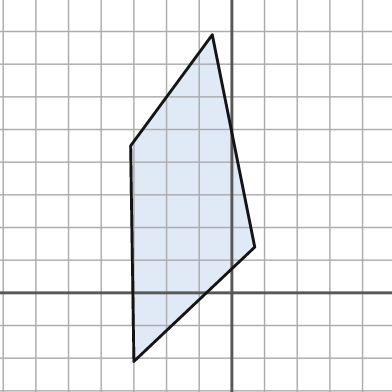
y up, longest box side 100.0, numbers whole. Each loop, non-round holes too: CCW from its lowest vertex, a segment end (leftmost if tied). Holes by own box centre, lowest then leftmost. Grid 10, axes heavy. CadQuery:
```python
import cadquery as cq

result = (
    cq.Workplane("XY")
    .moveTo(-30.0, -21.0)
    .lineTo(7.0, 14.0)
    .lineTo(-6.0, 79.0)
    .lineTo(-31.0, 45.0)
    .close()
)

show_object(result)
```